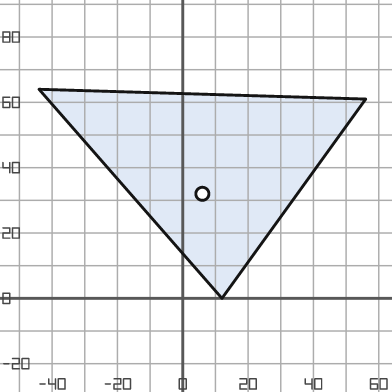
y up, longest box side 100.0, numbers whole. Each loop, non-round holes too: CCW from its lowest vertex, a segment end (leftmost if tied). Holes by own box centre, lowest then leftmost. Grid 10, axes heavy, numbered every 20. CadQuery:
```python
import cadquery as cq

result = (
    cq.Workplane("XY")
    .moveTo(12.0, 0.0)
    .lineTo(56.0, 61.0)
    .lineTo(-44.0, 64.0)
    .close()
    .moveTo(6.0, 32.0)
    .circle(2.0)
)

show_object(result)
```